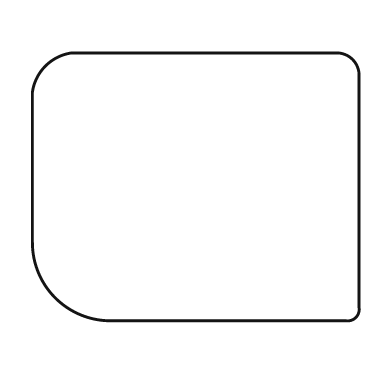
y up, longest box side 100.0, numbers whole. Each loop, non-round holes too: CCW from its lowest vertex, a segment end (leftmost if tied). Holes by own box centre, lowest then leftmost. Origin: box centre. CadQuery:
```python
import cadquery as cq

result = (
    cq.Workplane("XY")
    .moveTo(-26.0, -41.0)
    .lineTo(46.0, -41.0)
    .threePointArc((49.0, -40.0), (50.0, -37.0))
    .lineTo(50.0, 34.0)
    .threePointArc((48.0, 39.0), (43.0, 41.0))
    .lineTo(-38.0, 41.0)
    .threePointArc((-46.0, 37.0), (-50.0, 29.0))
    .lineTo(-50.0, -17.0)
    .threePointArc((-43.0, -34.0), (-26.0, -41.0))
    .close()
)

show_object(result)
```